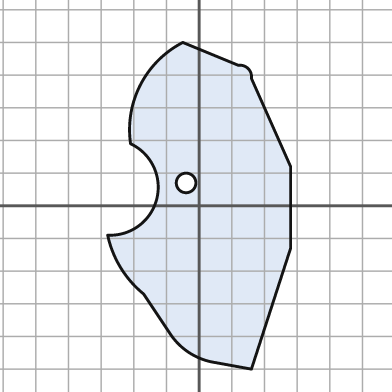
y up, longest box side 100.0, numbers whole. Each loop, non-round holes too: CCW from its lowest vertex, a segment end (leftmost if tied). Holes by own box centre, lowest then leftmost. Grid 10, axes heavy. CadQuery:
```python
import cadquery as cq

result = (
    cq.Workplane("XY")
    .moveTo(16.0, -50.0)
    .lineTo(28.0, -13.0)
    .lineTo(28.0, 12.0)
    .lineTo(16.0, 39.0)
    .threePointArc((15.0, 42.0), (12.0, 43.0))
    .lineTo(-5.0, 50.0)
    .threePointArc((-18.0, 37.0), (-21.0, 19.0))
    .threePointArc((-13.0, 2.0), (-28.0, -9.0))
    .threePointArc((-24.0, -19.0), (-17.0, -27.0))
    .lineTo(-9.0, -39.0)
    .threePointArc((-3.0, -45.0), (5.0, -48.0))
    .close()
    .moveTo(-4.0, 7.0)
    .circle(3.0)
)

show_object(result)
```